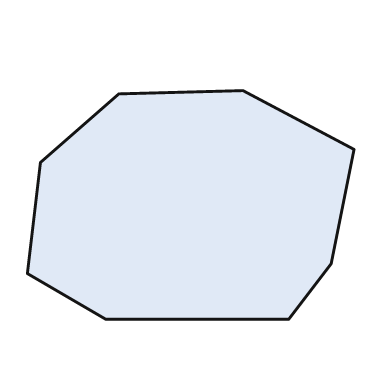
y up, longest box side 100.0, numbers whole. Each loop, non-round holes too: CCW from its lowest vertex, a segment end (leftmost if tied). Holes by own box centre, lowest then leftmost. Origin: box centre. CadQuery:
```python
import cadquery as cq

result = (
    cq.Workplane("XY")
    .moveTo(-26.0, -35.0)
    .lineTo(30.0, -35.0)
    .lineTo(43.0, -18.0)
    .lineTo(50.0, 17.0)
    .lineTo(16.0, 35.0)
    .lineTo(-22.0, 34.0)
    .lineTo(-46.0, 13.0)
    .lineTo(-50.0, -21.0)
    .close()
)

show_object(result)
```